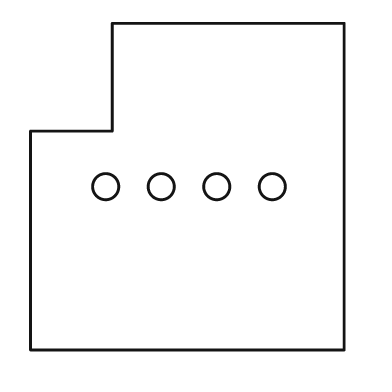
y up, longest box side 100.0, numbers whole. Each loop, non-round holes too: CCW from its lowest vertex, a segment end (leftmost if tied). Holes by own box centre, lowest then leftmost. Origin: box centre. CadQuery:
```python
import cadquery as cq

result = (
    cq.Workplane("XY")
    .moveTo(-48.0, -50.0)
    .lineTo(48.0, -50.0)
    .lineTo(48.0, 50.0)
    .lineTo(-23.0, 50.0)
    .lineTo(-23.0, 17.0)
    .lineTo(-48.0, 17.0)
    .close()
    .moveTo(-25.0, 0.0)
    .circle(4.0)
    .moveTo(-8.0, 0.0)
    .circle(4.0)
    .moveTo(9.0, 0.0)
    .circle(4.0)
    .moveTo(26.0, 0.0)
    .circle(4.0)
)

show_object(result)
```